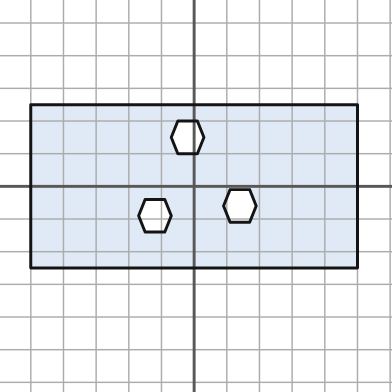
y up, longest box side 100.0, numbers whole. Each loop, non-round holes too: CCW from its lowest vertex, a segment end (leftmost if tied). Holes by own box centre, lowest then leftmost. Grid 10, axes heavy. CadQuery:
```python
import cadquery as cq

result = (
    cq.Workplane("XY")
    .moveTo(-50.0, -25.0)
    .lineTo(50.0, -25.0)
    .lineTo(50.0, 25.0)
    .lineTo(-50.0, 25.0)
    .close()
    .moveTo(-15.0, -14.0)
    .lineTo(-9.0, -14.0)
    .lineTo(-7.0, -9.0)
    .lineTo(-9.0, -4.0)
    .lineTo(-15.0, -4.0)
    .lineTo(-17.0, -9.0)
    .close()
    .moveTo(11.0, -11.0)
    .lineTo(17.0, -11.0)
    .lineTo(19.0, -6.0)
    .lineTo(17.0, -1.0)
    .lineTo(11.0, -1.0)
    .lineTo(9.0, -6.0)
    .close()
    .moveTo(-5.0, 10.0)
    .lineTo(1.0, 10.0)
    .lineTo(3.0, 15.0)
    .lineTo(1.0, 20.0)
    .lineTo(-5.0, 20.0)
    .lineTo(-7.0, 15.0)
    .close()
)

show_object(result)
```